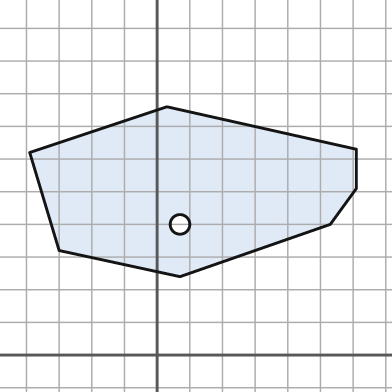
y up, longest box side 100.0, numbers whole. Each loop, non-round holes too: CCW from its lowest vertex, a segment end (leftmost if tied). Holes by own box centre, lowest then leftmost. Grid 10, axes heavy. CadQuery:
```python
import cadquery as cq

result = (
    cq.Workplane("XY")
    .moveTo(7.0, 24.0)
    .lineTo(53.0, 40.0)
    .lineTo(61.0, 51.0)
    .lineTo(61.0, 63.0)
    .lineTo(3.0, 76.0)
    .lineTo(-39.0, 62.0)
    .lineTo(-30.0, 32.0)
    .close()
    .moveTo(7.0, 40.0)
    .circle(3.0)
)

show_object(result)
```